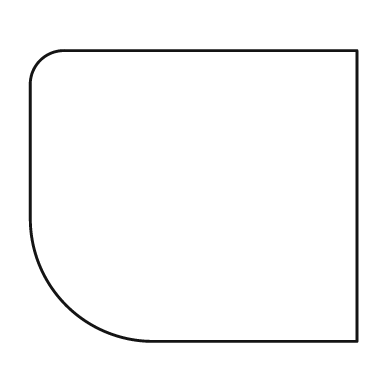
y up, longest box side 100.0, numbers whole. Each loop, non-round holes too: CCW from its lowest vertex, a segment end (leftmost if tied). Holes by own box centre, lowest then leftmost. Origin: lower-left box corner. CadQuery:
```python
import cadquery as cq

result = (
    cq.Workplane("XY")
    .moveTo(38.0, 0.0)
    .lineTo(100.0, 0.0)
    .lineTo(100.0, 89.0)
    .lineTo(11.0, 89.0)
    .threePointArc((3.0, 86.0), (0.0, 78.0))
    .lineTo(0.0, 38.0)
    .threePointArc((11.0, 11.0), (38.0, 0.0))
    .close()
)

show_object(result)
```